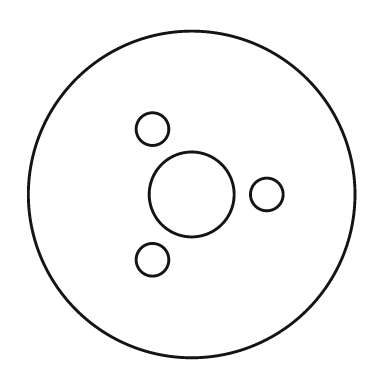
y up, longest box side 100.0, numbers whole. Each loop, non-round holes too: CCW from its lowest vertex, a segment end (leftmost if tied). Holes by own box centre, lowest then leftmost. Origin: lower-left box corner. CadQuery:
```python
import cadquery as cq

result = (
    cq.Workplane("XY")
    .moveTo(50.0, 50.0)
    .circle(50.0)
    .moveTo(38.0, 30.0)
    .circle(5.0)
    .moveTo(50.0, 50.0)
    .circle(13.0)
    .moveTo(73.0, 50.0)
    .circle(5.0)
    .moveTo(38.0, 70.0)
    .circle(5.0)
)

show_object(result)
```